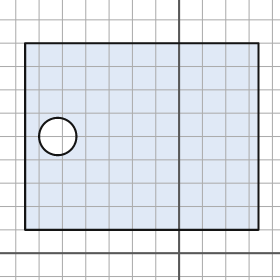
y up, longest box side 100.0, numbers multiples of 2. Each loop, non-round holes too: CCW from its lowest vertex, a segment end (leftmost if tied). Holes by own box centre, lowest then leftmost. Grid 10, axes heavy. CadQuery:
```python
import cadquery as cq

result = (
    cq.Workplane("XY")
    .moveTo(-66.0, 10.0)
    .lineTo(34.0, 10.0)
    .lineTo(34.0, 90.0)
    .lineTo(-66.0, 90.0)
    .close()
    .moveTo(-52.0, 50.0)
    .circle(8.0)
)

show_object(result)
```